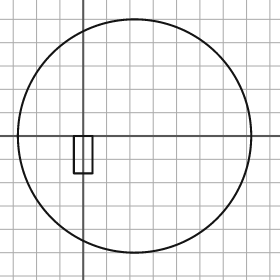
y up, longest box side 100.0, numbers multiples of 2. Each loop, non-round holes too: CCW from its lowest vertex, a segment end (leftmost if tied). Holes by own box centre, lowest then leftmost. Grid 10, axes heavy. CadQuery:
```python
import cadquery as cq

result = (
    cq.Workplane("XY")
    .moveTo(22.0, 0.0)
    .circle(50.0)
    .moveTo(-4.0, -16.0)
    .lineTo(4.0, -16.0)
    .lineTo(4.0, 0.0)
    .lineTo(-4.0, 0.0)
    .close()
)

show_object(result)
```